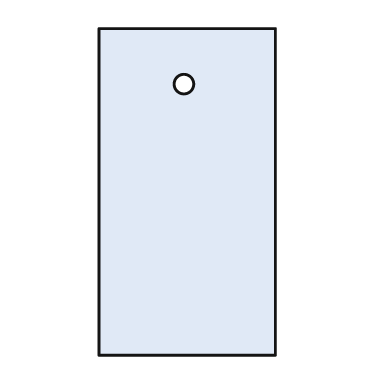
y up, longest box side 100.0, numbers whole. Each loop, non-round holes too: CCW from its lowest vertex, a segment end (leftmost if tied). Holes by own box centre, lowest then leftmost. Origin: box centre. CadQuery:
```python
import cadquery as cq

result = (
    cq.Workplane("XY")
    .moveTo(-27.0, -50.0)
    .lineTo(27.0, -50.0)
    .lineTo(27.0, 50.0)
    .lineTo(-27.0, 50.0)
    .close()
    .moveTo(-1.0, 33.0)
    .circle(3.0)
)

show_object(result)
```